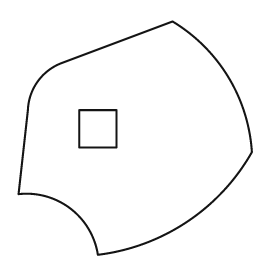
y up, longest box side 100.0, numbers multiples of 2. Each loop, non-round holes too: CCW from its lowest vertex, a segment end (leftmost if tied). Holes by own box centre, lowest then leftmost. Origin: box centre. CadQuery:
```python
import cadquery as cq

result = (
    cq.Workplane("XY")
    .moveTo(-16.0, -50.0)
    .threePointArc((22.0, -36.0), (50.0, -6.0))
    .threePointArc((40.0, 26.0), (16.0, 50.0))
    .lineTo(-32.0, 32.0)
    .threePointArc((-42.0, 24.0), (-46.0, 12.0))
    .lineTo(-50.0, -24.0)
    .threePointArc((-28.0, -30.0), (-16.0, -50.0))
    .close()
    .moveTo(-24.0, -4.0)
    .lineTo(-8.0, -4.0)
    .lineTo(-8.0, 12.0)
    .lineTo(-24.0, 12.0)
    .close()
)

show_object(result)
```